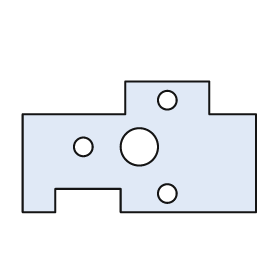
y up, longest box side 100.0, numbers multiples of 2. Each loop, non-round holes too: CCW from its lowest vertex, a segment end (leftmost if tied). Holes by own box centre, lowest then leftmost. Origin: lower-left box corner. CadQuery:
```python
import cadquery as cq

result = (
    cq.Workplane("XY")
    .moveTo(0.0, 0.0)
    .lineTo(14.0, 0.0)
    .lineTo(14.0, 10.0)
    .lineTo(42.0, 10.0)
    .lineTo(42.0, 0.0)
    .lineTo(100.0, 0.0)
    .lineTo(100.0, 42.0)
    .lineTo(80.0, 42.0)
    .lineTo(80.0, 56.0)
    .lineTo(44.0, 56.0)
    .lineTo(44.0, 42.0)
    .lineTo(0.0, 42.0)
    .close()
    .moveTo(62.0, 8.0)
    .circle(4.0)
    .moveTo(26.0, 28.0)
    .circle(4.0)
    .moveTo(50.0, 28.0)
    .circle(8.0)
    .moveTo(62.0, 48.0)
    .circle(4.0)
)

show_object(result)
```